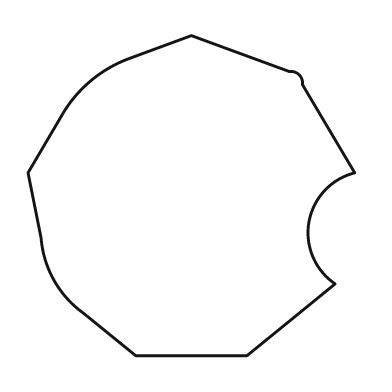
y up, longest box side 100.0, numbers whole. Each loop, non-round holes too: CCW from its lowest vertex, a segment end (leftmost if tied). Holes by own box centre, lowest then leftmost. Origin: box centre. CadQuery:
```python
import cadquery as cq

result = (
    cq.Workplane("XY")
    .moveTo(-17.0, -49.0)
    .lineTo(17.0, -49.0)
    .lineTo(44.0, -27.0)
    .threePointArc((36.0, -8.0), (50.0, 7.0))
    .lineTo(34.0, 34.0)
    .threePointArc((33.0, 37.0), (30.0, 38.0))
    .lineTo(0.0, 49.0)
    .lineTo(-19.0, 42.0)
    .threePointArc((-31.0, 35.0), (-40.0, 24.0))
    .lineTo(-50.0, 7.0)
    .lineTo(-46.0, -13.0)
    .threePointArc((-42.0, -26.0), (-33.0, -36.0))
    .close()
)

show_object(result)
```